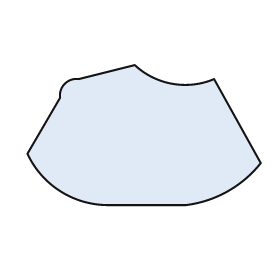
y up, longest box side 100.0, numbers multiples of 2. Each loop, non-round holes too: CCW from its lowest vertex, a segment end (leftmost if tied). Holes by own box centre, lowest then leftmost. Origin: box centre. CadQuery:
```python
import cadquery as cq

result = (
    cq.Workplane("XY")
    .moveTo(-16.0, -30.0)
    .lineTo(18.0, -30.0)
    .threePointArc((36.0, -24.0), (50.0, -12.0))
    .lineTo(30.0, 24.0)
    .threePointArc((12.0, 22.0), (-4.0, 30.0))
    .lineTo(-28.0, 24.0)
    .threePointArc((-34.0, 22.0), (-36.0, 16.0))
    .lineTo(-50.0, -8.0)
    .threePointArc((-36.0, -24.0), (-16.0, -30.0))
    .close()
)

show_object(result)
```